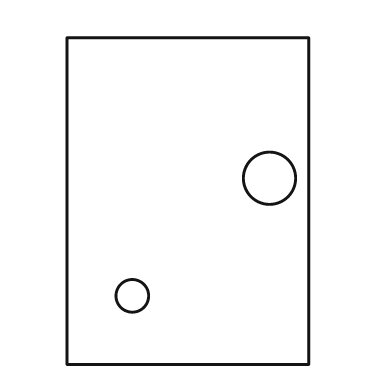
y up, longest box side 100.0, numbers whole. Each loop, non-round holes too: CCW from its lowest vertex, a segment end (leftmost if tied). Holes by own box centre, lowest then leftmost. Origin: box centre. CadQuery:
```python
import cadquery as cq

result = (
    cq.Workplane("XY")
    .moveTo(-37.0, -50.0)
    .lineTo(37.0, -50.0)
    .lineTo(37.0, 50.0)
    .lineTo(-37.0, 50.0)
    .close()
    .moveTo(-17.0, -29.0)
    .circle(5.0)
    .moveTo(25.0, 7.0)
    .circle(8.0)
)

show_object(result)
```